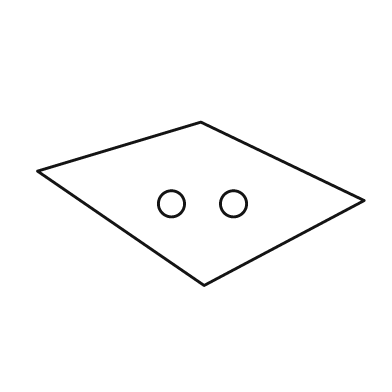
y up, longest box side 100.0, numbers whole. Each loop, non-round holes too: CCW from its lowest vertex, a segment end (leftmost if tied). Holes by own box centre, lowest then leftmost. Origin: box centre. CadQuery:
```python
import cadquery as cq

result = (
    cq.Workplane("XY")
    .moveTo(1.0, -25.0)
    .lineTo(50.0, 1.0)
    .lineTo(0.0, 25.0)
    .lineTo(-50.0, 10.0)
    .close()
    .moveTo(-9.0, 0.0)
    .circle(4.0)
    .moveTo(10.0, 0.0)
    .circle(4.0)
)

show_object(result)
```